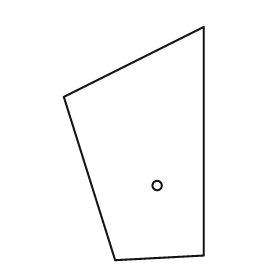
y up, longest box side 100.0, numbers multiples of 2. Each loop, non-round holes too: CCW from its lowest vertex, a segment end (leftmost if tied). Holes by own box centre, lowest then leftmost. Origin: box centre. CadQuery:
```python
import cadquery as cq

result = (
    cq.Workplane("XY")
    .moveTo(-8.0, -50.0)
    .lineTo(30.0, -48.0)
    .lineTo(30.0, 50.0)
    .lineTo(-30.0, 20.0)
    .close()
    .moveTo(10.0, -18.0)
    .circle(2.0)
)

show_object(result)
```